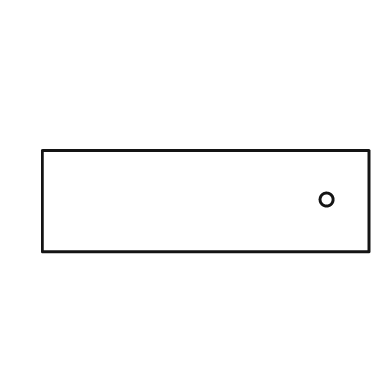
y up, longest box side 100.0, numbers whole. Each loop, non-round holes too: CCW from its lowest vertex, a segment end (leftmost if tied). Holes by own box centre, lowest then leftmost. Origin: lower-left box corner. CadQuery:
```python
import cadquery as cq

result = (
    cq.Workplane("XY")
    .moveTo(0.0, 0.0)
    .lineTo(100.0, 0.0)
    .lineTo(100.0, 31.0)
    .lineTo(0.0, 31.0)
    .close()
    .moveTo(87.0, 16.0)
    .circle(2.0)
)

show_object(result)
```